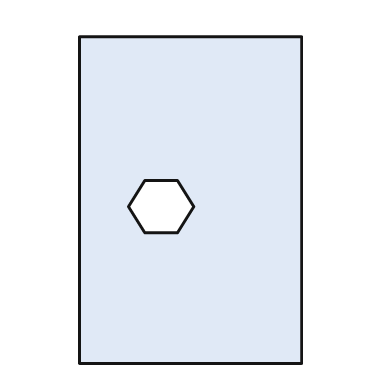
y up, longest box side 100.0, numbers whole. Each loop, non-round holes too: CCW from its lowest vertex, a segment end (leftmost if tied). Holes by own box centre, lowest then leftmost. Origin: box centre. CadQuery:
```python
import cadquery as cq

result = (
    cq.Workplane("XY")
    .moveTo(-34.0, -50.0)
    .lineTo(34.0, -50.0)
    .lineTo(34.0, 50.0)
    .lineTo(-34.0, 50.0)
    .close()
    .moveTo(-14.0, -10.0)
    .lineTo(-4.0, -10.0)
    .lineTo(1.0, -2.0)
    .lineTo(-4.0, 6.0)
    .lineTo(-14.0, 6.0)
    .lineTo(-19.0, -2.0)
    .close()
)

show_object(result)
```